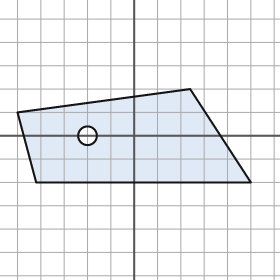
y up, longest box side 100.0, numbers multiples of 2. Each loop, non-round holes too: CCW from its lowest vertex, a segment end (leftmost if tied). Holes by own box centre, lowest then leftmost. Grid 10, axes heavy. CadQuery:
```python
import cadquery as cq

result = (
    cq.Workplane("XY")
    .moveTo(-42.0, -20.0)
    .lineTo(50.0, -20.0)
    .lineTo(24.0, 20.0)
    .lineTo(-50.0, 10.0)
    .close()
    .moveTo(-20.0, 0.0)
    .circle(4.0)
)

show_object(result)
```